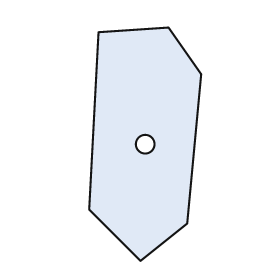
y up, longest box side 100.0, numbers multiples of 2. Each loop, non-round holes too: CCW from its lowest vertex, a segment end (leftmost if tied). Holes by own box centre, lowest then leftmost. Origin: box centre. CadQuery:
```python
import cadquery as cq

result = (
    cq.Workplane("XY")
    .moveTo(-2.0, -50.0)
    .lineTo(18.0, -34.0)
    .lineTo(24.0, 30.0)
    .lineTo(10.0, 50.0)
    .lineTo(-20.0, 48.0)
    .lineTo(-24.0, -28.0)
    .close()
    .moveTo(0.0, 0.0)
    .circle(4.0)
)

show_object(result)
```